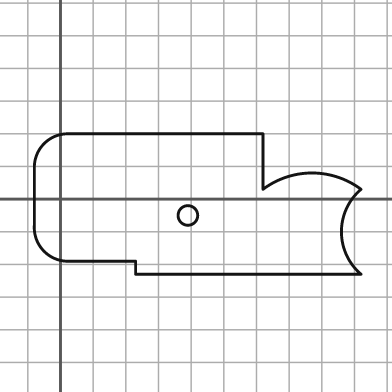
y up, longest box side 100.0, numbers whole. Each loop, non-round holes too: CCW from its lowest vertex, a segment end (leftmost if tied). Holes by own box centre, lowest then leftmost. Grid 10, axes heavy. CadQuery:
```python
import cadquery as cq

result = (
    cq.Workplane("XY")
    .moveTo(23.0, -23.0)
    .lineTo(92.0, -23.0)
    .threePointArc((86.0, -10.0), (92.0, 3.0))
    .threePointArc((77.0, 8.0), (62.0, 3.0))
    .lineTo(62.0, 20.0)
    .lineTo(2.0, 20.0)
    .threePointArc((-5.0, 17.0), (-8.0, 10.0))
    .lineTo(-8.0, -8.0)
    .threePointArc((-5.0, -16.0), (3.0, -19.0))
    .lineTo(23.0, -19.0)
    .close()
    .moveTo(39.0, -5.0)
    .circle(3.0)
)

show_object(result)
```